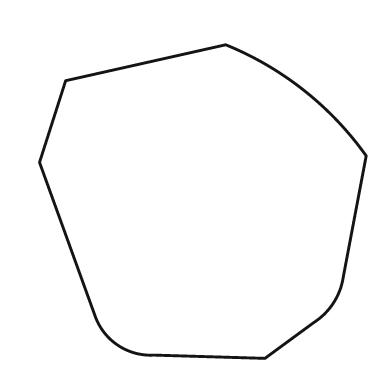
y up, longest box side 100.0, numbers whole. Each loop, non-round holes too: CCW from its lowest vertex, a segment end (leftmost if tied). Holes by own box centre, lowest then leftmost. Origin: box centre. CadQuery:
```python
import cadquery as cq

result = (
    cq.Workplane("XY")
    .moveTo(19.0, -48.0)
    .lineTo(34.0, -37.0)
    .threePointArc((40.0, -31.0), (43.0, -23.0))
    .lineTo(50.0, 14.0)
    .threePointArc((31.0, 34.0), (7.0, 48.0))
    .lineTo(-42.0, 37.0)
    .lineTo(-50.0, 12.0)
    .lineTo(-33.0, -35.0)
    .threePointArc((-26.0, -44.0), (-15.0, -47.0))
    .close()
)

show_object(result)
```